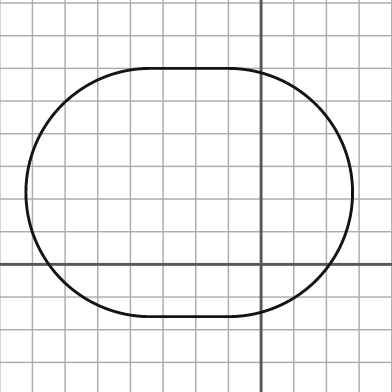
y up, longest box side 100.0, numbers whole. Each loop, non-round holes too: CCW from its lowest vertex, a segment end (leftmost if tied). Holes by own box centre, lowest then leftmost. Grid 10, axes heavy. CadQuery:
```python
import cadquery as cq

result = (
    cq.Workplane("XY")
    .moveTo(-34.0, -16.0)
    .lineTo(-10.0, -16.0)
    .threePointArc((28.0, 22.0), (-10.0, 60.0))
    .lineTo(-34.0, 60.0)
    .threePointArc((-72.0, 22.0), (-34.0, -16.0))
    .close()
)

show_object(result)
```